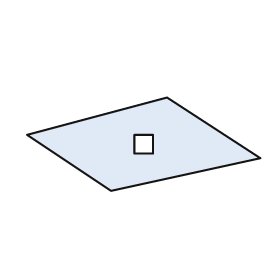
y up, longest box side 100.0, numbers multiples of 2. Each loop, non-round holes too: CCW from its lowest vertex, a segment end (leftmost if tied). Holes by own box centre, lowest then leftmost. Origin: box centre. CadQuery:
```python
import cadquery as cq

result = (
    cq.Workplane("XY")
    .moveTo(-14.0, -20.0)
    .lineTo(50.0, -6.0)
    .lineTo(10.0, 20.0)
    .lineTo(-50.0, 4.0)
    .close()
    .moveTo(-4.0, -4.0)
    .lineTo(4.0, -4.0)
    .lineTo(4.0, 4.0)
    .lineTo(-4.0, 4.0)
    .close()
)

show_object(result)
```